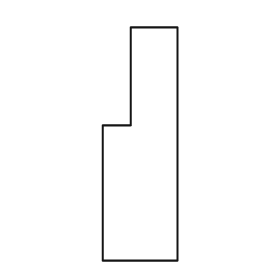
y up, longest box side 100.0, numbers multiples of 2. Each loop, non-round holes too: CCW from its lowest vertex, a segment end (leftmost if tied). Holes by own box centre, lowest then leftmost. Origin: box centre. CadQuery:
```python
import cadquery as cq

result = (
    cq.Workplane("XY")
    .moveTo(-16.0, -50.0)
    .lineTo(16.0, -50.0)
    .lineTo(16.0, 50.0)
    .lineTo(-4.0, 50.0)
    .lineTo(-4.0, 8.0)
    .lineTo(-16.0, 8.0)
    .close()
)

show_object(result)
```